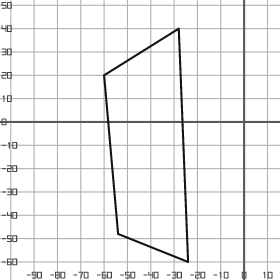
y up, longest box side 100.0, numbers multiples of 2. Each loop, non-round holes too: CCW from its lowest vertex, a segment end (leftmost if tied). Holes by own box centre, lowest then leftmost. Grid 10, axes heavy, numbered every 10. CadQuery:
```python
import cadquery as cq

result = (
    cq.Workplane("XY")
    .moveTo(-24.0, -60.0)
    .lineTo(-28.0, 40.0)
    .lineTo(-60.0, 20.0)
    .lineTo(-54.0, -48.0)
    .close()
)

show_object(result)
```